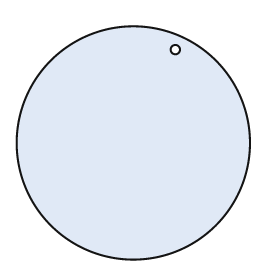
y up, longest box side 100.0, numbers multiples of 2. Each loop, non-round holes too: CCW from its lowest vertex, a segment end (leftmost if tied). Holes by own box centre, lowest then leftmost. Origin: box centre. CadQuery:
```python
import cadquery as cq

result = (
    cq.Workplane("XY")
    .moveTo(0.0, 0.0)
    .circle(50.0)
    .moveTo(18.0, 40.0)
    .circle(2.0)
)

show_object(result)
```